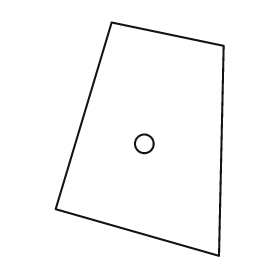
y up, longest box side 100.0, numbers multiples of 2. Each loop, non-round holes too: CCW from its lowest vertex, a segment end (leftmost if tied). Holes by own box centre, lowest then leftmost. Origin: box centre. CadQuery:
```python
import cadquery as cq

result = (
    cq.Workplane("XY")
    .moveTo(34.0, -50.0)
    .lineTo(36.0, 40.0)
    .lineTo(-12.0, 50.0)
    .lineTo(-36.0, -30.0)
    .close()
    .moveTo(2.0, -2.0)
    .circle(4.0)
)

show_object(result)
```